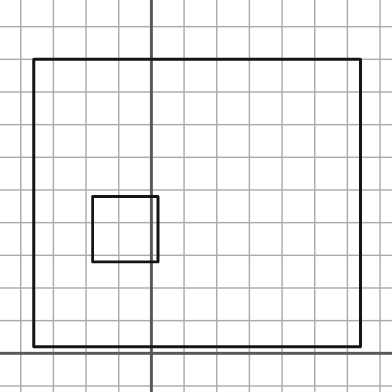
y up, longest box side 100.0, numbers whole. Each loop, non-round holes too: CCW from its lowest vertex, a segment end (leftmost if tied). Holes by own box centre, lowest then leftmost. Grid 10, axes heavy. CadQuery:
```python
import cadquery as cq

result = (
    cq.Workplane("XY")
    .moveTo(-36.0, 2.0)
    .lineTo(64.0, 2.0)
    .lineTo(64.0, 90.0)
    .lineTo(-36.0, 90.0)
    .close()
    .moveTo(-18.0, 28.0)
    .lineTo(2.0, 28.0)
    .lineTo(2.0, 48.0)
    .lineTo(-18.0, 48.0)
    .close()
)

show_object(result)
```